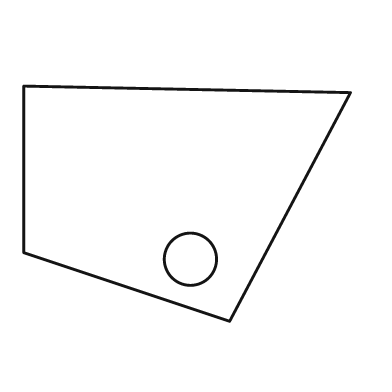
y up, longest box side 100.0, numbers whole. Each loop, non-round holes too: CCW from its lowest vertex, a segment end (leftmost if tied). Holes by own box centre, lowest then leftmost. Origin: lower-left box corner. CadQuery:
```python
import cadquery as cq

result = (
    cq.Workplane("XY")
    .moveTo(63.0, 0.0)
    .lineTo(100.0, 70.0)
    .lineTo(0.0, 72.0)
    .lineTo(0.0, 21.0)
    .close()
    .moveTo(51.0, 19.0)
    .circle(8.0)
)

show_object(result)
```